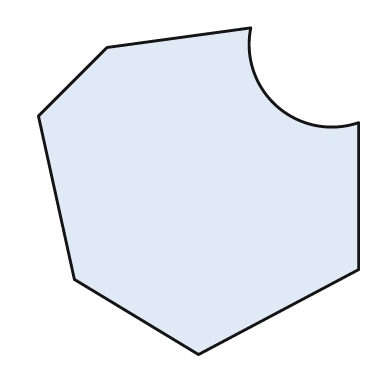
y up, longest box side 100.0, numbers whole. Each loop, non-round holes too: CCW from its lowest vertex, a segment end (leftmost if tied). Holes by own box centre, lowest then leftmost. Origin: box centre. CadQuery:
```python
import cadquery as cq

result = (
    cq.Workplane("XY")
    .moveTo(0.0, -50.0)
    .lineTo(49.0, -24.0)
    .lineTo(49.0, 21.0)
    .threePointArc((24.0, 26.0), (16.0, 50.0))
    .lineTo(-28.0, 44.0)
    .lineTo(-49.0, 23.0)
    .lineTo(-38.0, -27.0)
    .close()
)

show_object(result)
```